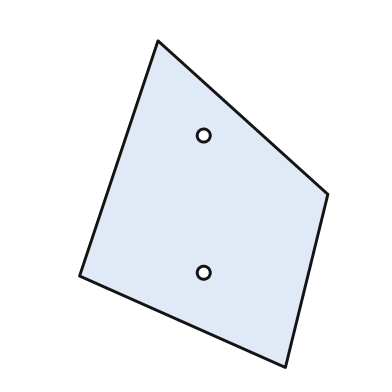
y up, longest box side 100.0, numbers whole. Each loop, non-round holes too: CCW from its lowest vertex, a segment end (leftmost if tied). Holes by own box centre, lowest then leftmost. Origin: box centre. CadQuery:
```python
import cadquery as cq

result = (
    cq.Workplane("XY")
    .moveTo(25.0, -50.0)
    .lineTo(38.0, 3.0)
    .lineTo(-14.0, 50.0)
    .lineTo(-38.0, -22.0)
    .close()
    .moveTo(0.0, -21.0)
    .circle(2.0)
    .moveTo(0.0, 21.0)
    .circle(2.0)
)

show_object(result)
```